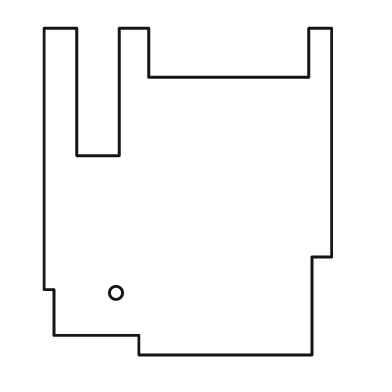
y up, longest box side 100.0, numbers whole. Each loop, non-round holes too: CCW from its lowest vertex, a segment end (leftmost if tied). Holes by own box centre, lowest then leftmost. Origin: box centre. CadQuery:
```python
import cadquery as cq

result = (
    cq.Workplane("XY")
    .moveTo(-15.0, -50.0)
    .lineTo(38.0, -50.0)
    .lineTo(38.0, -20.0)
    .lineTo(44.0, -20.0)
    .lineTo(44.0, 50.0)
    .lineTo(37.0, 50.0)
    .lineTo(37.0, 35.0)
    .lineTo(-12.0, 35.0)
    .lineTo(-12.0, 50.0)
    .lineTo(-21.0, 50.0)
    .lineTo(-21.0, 11.0)
    .lineTo(-34.0, 11.0)
    .lineTo(-34.0, 50.0)
    .lineTo(-44.0, 50.0)
    .lineTo(-44.0, -30.0)
    .lineTo(-41.0, -30.0)
    .lineTo(-41.0, -44.0)
    .lineTo(-15.0, -44.0)
    .close()
    .moveTo(-22.0, -31.0)
    .circle(2.0)
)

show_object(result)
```